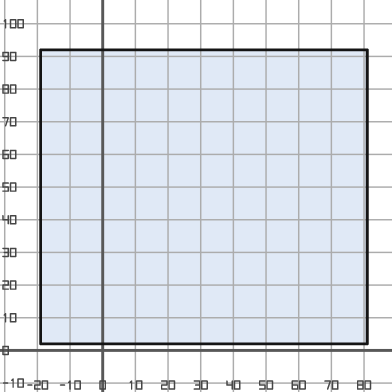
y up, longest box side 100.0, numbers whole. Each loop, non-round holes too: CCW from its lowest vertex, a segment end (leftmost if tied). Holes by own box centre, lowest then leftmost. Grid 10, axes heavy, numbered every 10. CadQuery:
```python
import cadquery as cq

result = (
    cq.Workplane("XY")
    .moveTo(-19.0, 2.0)
    .lineTo(81.0, 2.0)
    .lineTo(81.0, 92.0)
    .lineTo(-19.0, 92.0)
    .close()
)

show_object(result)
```